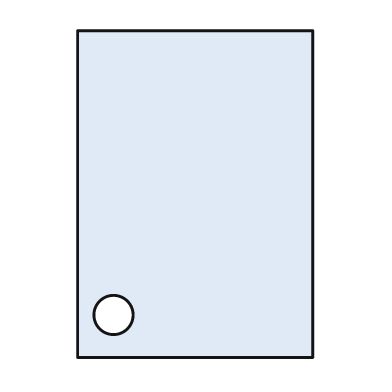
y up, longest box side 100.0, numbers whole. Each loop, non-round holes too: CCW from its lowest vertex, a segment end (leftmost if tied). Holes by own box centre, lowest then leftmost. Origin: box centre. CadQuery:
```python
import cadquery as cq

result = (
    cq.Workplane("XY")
    .moveTo(-36.0, -50.0)
    .lineTo(36.0, -50.0)
    .lineTo(36.0, 50.0)
    .lineTo(-36.0, 50.0)
    .close()
    .moveTo(-25.0, -37.0)
    .circle(6.0)
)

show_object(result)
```